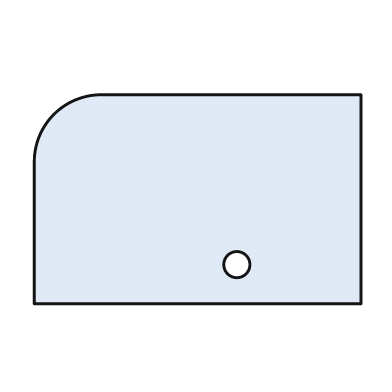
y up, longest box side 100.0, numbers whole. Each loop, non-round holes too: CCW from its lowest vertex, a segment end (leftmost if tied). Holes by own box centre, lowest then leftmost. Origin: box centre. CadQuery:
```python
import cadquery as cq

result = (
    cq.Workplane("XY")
    .moveTo(-50.0, -32.0)
    .lineTo(50.0, -32.0)
    .lineTo(50.0, 32.0)
    .lineTo(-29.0, 32.0)
    .threePointArc((-44.0, 26.0), (-50.0, 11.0))
    .close()
    .moveTo(12.0, -20.0)
    .circle(4.0)
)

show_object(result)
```